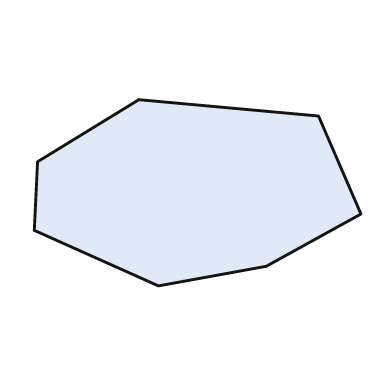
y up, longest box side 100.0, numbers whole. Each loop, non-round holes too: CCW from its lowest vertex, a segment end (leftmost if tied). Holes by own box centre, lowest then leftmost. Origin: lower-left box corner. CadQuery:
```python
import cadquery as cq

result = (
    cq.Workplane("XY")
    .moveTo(38.0, 0.0)
    .lineTo(71.0, 6.0)
    .lineTo(100.0, 22.0)
    .lineTo(87.0, 52.0)
    .lineTo(32.0, 57.0)
    .lineTo(1.0, 38.0)
    .lineTo(0.0, 17.0)
    .close()
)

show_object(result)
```